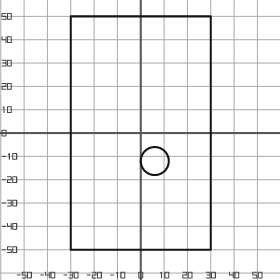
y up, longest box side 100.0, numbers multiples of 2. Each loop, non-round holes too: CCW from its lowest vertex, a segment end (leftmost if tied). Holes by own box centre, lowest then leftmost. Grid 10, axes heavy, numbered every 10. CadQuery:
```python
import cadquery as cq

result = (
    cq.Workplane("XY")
    .moveTo(-30.0, -50.0)
    .lineTo(30.0, -50.0)
    .lineTo(30.0, 50.0)
    .lineTo(-30.0, 50.0)
    .close()
    .moveTo(6.0, -12.0)
    .circle(6.0)
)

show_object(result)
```